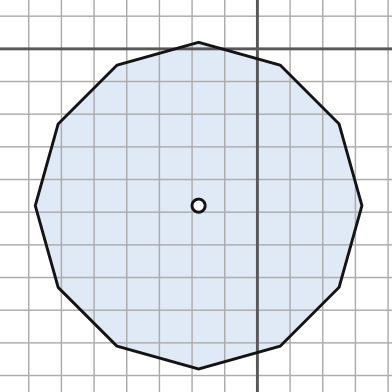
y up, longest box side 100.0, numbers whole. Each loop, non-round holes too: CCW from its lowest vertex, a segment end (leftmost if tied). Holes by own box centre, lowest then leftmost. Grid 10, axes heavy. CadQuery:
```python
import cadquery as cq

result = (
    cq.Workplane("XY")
    .moveTo(-18.0, -98.0)
    .lineTo(7.0, -91.0)
    .lineTo(25.0, -73.0)
    .lineTo(32.0, -48.0)
    .lineTo(25.0, -23.0)
    .lineTo(7.0, -5.0)
    .lineTo(-18.0, 2.0)
    .lineTo(-43.0, -5.0)
    .lineTo(-61.0, -23.0)
    .lineTo(-68.0, -48.0)
    .lineTo(-61.0, -73.0)
    .lineTo(-43.0, -91.0)
    .close()
    .moveTo(-18.0, -48.0)
    .circle(2.0)
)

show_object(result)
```